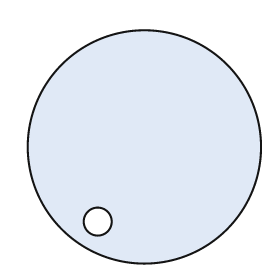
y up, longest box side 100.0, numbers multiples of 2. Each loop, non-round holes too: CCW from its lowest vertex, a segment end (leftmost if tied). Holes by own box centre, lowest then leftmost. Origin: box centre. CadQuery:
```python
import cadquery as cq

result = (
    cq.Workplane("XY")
    .moveTo(0.0, 0.0)
    .circle(50.0)
    .moveTo(-20.0, -32.0)
    .circle(6.0)
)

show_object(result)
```